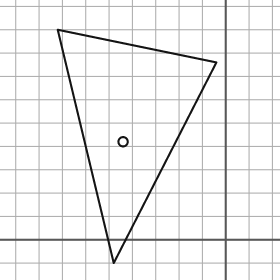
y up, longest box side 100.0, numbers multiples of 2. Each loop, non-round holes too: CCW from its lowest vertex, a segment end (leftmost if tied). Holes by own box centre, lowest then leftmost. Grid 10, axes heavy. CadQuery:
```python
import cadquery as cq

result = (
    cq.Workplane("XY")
    .moveTo(-48.0, -10.0)
    .lineTo(-4.0, 76.0)
    .lineTo(-72.0, 90.0)
    .close()
    .moveTo(-44.0, 42.0)
    .circle(2.0)
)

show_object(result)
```